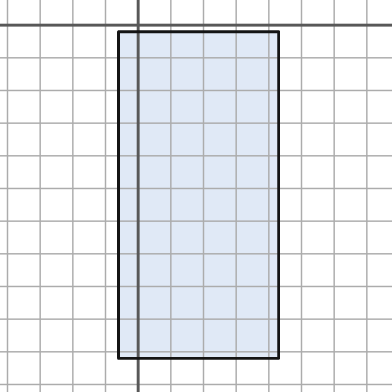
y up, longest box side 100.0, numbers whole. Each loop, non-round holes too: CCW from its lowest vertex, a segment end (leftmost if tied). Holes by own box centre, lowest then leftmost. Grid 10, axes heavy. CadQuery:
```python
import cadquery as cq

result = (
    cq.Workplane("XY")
    .moveTo(-6.0, -102.0)
    .lineTo(43.0, -102.0)
    .lineTo(43.0, -2.0)
    .lineTo(-6.0, -2.0)
    .close()
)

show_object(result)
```